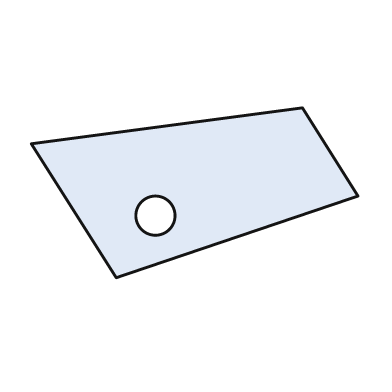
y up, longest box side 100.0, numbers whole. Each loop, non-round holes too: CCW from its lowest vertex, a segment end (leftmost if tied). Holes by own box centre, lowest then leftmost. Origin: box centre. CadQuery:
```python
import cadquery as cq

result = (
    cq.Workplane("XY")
    .moveTo(-24.0, -26.0)
    .lineTo(50.0, -1.0)
    .lineTo(33.0, 26.0)
    .lineTo(-50.0, 15.0)
    .close()
    .moveTo(-12.0, -7.0)
    .circle(6.0)
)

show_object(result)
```